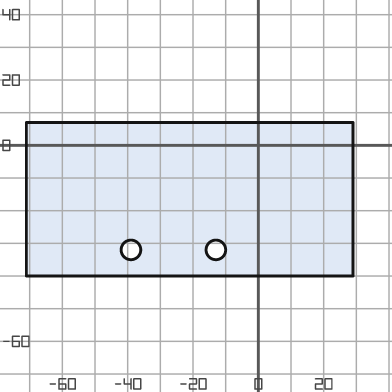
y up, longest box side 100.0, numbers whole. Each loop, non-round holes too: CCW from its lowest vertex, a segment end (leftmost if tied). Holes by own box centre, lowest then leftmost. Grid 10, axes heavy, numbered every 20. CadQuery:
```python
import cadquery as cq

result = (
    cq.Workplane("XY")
    .moveTo(-71.0, -40.0)
    .lineTo(29.0, -40.0)
    .lineTo(29.0, 7.0)
    .lineTo(-71.0, 7.0)
    .close()
    .moveTo(-39.0, -32.0)
    .circle(3.0)
    .moveTo(-13.0, -32.0)
    .circle(3.0)
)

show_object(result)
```